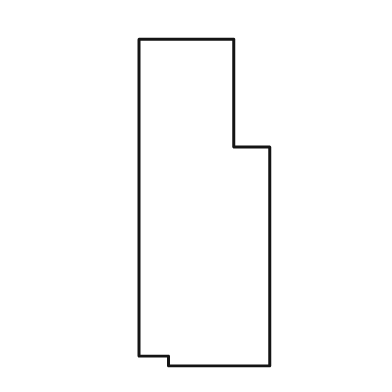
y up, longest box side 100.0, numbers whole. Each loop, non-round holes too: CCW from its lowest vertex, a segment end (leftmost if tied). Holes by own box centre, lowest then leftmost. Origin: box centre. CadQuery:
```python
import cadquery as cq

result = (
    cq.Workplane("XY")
    .moveTo(-11.0, -50.0)
    .lineTo(20.0, -50.0)
    .lineTo(20.0, 17.0)
    .lineTo(9.0, 17.0)
    .lineTo(9.0, 50.0)
    .lineTo(-20.0, 50.0)
    .lineTo(-20.0, -47.0)
    .lineTo(-11.0, -47.0)
    .close()
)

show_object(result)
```